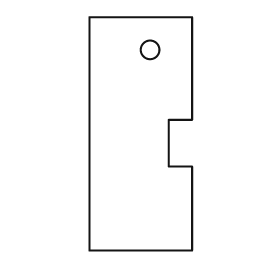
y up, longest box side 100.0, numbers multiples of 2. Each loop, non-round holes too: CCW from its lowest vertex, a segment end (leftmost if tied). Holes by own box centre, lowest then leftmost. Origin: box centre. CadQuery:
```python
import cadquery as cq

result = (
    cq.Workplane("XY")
    .moveTo(-22.0, -50.0)
    .lineTo(22.0, -50.0)
    .lineTo(22.0, -14.0)
    .lineTo(12.0, -14.0)
    .lineTo(12.0, 6.0)
    .lineTo(22.0, 6.0)
    .lineTo(22.0, 50.0)
    .lineTo(-22.0, 50.0)
    .close()
    .moveTo(4.0, 36.0)
    .circle(4.0)
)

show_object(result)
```